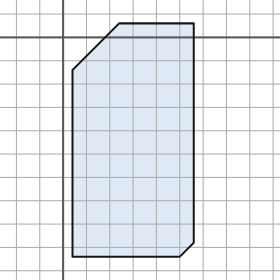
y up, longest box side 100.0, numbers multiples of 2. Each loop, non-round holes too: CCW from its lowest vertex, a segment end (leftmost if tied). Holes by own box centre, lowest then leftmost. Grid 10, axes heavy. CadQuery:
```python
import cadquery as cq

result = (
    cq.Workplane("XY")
    .moveTo(4.0, -94.0)
    .lineTo(50.0, -94.0)
    .lineTo(56.0, -88.0)
    .lineTo(56.0, 6.0)
    .lineTo(24.0, 6.0)
    .lineTo(4.0, -14.0)
    .close()
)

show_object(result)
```